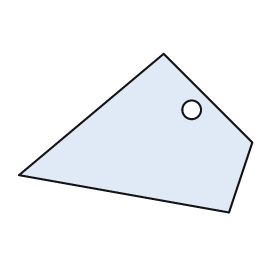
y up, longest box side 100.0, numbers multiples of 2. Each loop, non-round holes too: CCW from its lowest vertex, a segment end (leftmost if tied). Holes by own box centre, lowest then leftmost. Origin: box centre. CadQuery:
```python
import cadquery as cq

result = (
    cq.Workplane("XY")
    .moveTo(40.0, -34.0)
    .lineTo(50.0, -4.0)
    .lineTo(12.0, 34.0)
    .lineTo(-50.0, -18.0)
    .close()
    .moveTo(24.0, 10.0)
    .circle(4.0)
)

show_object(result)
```